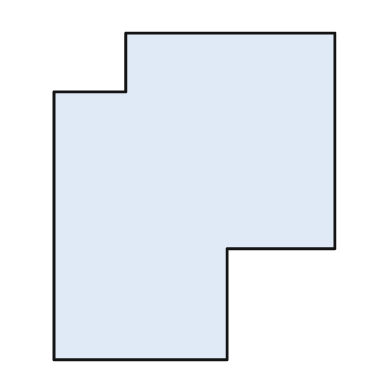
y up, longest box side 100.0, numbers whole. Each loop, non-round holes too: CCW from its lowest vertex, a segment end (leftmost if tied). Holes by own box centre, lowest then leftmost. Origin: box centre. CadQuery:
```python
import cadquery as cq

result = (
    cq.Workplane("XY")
    .moveTo(-43.0, -50.0)
    .lineTo(10.0, -50.0)
    .lineTo(10.0, -16.0)
    .lineTo(43.0, -16.0)
    .lineTo(43.0, 50.0)
    .lineTo(-21.0, 50.0)
    .lineTo(-21.0, 32.0)
    .lineTo(-43.0, 32.0)
    .close()
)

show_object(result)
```